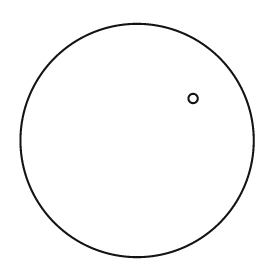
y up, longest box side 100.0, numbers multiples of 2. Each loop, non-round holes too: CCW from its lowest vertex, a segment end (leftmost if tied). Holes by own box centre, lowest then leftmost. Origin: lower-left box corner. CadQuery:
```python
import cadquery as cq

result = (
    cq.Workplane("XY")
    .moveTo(50.0, 50.0)
    .circle(50.0)
    .moveTo(74.0, 68.0)
    .circle(2.0)
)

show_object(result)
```